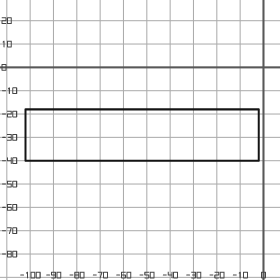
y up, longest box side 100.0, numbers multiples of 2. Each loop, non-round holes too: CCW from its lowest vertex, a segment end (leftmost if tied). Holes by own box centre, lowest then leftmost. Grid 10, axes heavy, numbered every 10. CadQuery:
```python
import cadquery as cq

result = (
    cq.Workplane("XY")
    .moveTo(-102.0, -40.0)
    .lineTo(-2.0, -40.0)
    .lineTo(-2.0, -18.0)
    .lineTo(-102.0, -18.0)
    .close()
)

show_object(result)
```